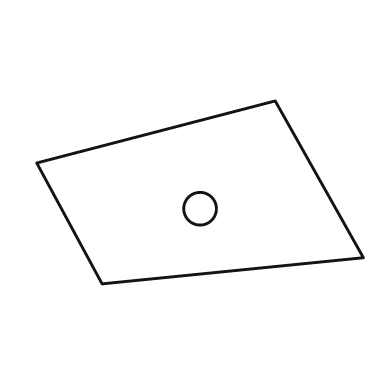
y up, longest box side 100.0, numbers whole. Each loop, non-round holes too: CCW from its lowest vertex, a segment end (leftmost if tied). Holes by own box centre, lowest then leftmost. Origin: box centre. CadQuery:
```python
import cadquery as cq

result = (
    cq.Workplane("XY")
    .moveTo(-30.0, -28.0)
    .lineTo(50.0, -20.0)
    .lineTo(23.0, 28.0)
    .lineTo(-50.0, 9.0)
    .close()
    .moveTo(0.0, -5.0)
    .circle(5.0)
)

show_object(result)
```